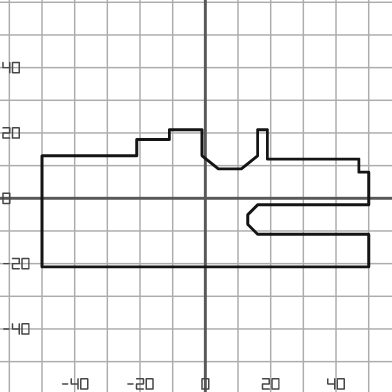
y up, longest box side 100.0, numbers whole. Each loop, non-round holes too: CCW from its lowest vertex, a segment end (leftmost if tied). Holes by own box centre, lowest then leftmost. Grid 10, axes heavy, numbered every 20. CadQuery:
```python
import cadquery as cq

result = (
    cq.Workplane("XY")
    .moveTo(-50.0, -21.0)
    .lineTo(50.0, -21.0)
    .lineTo(50.0, -11.0)
    .lineTo(16.0, -11.0)
    .lineTo(13.0, -8.0)
    .lineTo(13.0, -5.0)
    .lineTo(16.0, -2.0)
    .lineTo(50.0, -2.0)
    .lineTo(50.0, 8.0)
    .lineTo(47.0, 8.0)
    .lineTo(47.0, 12.0)
    .lineTo(19.0, 12.0)
    .lineTo(19.0, 21.0)
    .lineTo(16.0, 21.0)
    .lineTo(16.0, 13.0)
    .lineTo(11.0, 9.0)
    .lineTo(4.0, 9.0)
    .lineTo(-1.0, 13.0)
    .lineTo(-1.0, 21.0)
    .lineTo(-11.0, 21.0)
    .lineTo(-11.0, 18.0)
    .lineTo(-21.0, 18.0)
    .lineTo(-21.0, 13.0)
    .lineTo(-50.0, 13.0)
    .close()
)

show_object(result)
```